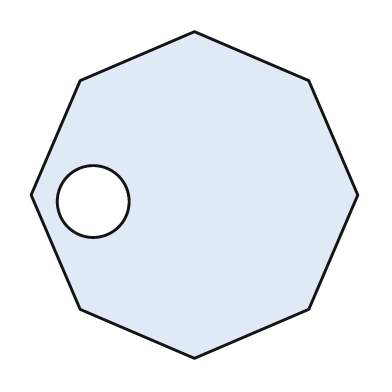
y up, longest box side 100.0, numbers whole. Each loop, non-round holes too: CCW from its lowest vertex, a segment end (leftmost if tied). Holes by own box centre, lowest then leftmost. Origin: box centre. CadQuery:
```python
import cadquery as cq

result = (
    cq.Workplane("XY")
    .moveTo(0.0, -50.0)
    .lineTo(35.0, -35.0)
    .lineTo(50.0, 0.0)
    .lineTo(35.0, 35.0)
    .lineTo(0.0, 50.0)
    .lineTo(-35.0, 35.0)
    .lineTo(-50.0, 0.0)
    .lineTo(-35.0, -35.0)
    .close()
    .moveTo(-31.0, -2.0)
    .circle(11.0)
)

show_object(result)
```